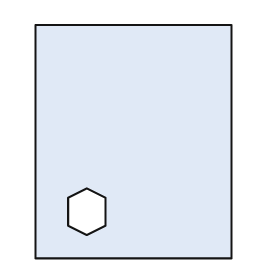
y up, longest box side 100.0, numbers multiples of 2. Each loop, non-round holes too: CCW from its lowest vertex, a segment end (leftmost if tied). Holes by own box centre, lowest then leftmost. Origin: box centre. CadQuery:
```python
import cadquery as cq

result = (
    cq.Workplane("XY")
    .moveTo(-42.0, -50.0)
    .lineTo(42.0, -50.0)
    .lineTo(42.0, 50.0)
    .lineTo(-42.0, 50.0)
    .close()
    .moveTo(-20.0, -40.0)
    .lineTo(-12.0, -36.0)
    .lineTo(-12.0, -24.0)
    .lineTo(-20.0, -20.0)
    .lineTo(-28.0, -24.0)
    .lineTo(-28.0, -36.0)
    .close()
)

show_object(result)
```